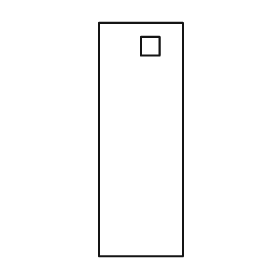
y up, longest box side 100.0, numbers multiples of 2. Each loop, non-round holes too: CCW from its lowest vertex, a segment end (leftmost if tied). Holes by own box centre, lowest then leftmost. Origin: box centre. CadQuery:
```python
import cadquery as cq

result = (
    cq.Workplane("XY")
    .moveTo(-18.0, -50.0)
    .lineTo(18.0, -50.0)
    .lineTo(18.0, 50.0)
    .lineTo(-18.0, 50.0)
    .close()
    .moveTo(0.0, 36.0)
    .lineTo(8.0, 36.0)
    .lineTo(8.0, 44.0)
    .lineTo(0.0, 44.0)
    .close()
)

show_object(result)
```